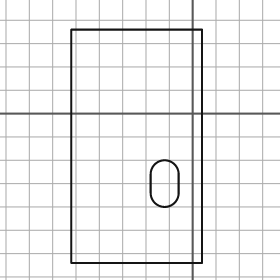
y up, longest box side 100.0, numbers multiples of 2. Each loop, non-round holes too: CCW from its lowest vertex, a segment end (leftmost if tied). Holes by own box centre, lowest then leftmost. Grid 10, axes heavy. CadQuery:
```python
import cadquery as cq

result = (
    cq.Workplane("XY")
    .moveTo(-52.0, -64.0)
    .lineTo(4.0, -64.0)
    .lineTo(4.0, 36.0)
    .lineTo(-52.0, 36.0)
    .close()
    .moveTo(-18.0, -34.0)
    .threePointArc((-12.0, -40.0), (-6.0, -34.0))
    .lineTo(-6.0, -26.0)
    .threePointArc((-12.0, -20.0), (-18.0, -26.0))
    .close()
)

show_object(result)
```